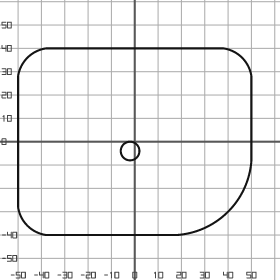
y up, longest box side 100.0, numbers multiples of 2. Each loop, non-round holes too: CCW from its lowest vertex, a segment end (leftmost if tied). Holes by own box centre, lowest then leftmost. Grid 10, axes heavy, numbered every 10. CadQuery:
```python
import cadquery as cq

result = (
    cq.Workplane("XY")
    .moveTo(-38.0, -40.0)
    .lineTo(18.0, -40.0)
    .threePointArc((40.0, -30.0), (50.0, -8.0))
    .lineTo(50.0, 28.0)
    .threePointArc((46.0, 36.0), (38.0, 40.0))
    .lineTo(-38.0, 40.0)
    .threePointArc((-46.0, 36.0), (-50.0, 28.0))
    .lineTo(-50.0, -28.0)
    .threePointArc((-46.0, -36.0), (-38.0, -40.0))
    .close()
    .moveTo(-2.0, -4.0)
    .circle(4.0)
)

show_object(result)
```